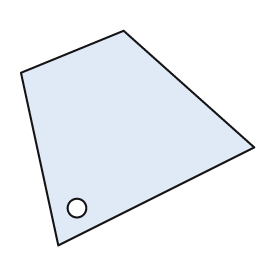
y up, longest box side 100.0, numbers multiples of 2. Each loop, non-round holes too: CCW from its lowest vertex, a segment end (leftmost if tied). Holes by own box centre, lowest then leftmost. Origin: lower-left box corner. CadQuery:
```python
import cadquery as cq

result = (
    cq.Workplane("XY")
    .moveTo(16.0, 0.0)
    .lineTo(100.0, 42.0)
    .lineTo(44.0, 92.0)
    .lineTo(0.0, 74.0)
    .close()
    .moveTo(24.0, 16.0)
    .circle(4.0)
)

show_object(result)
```